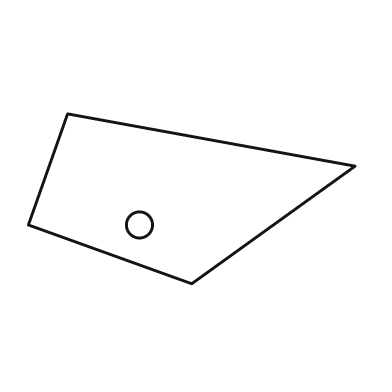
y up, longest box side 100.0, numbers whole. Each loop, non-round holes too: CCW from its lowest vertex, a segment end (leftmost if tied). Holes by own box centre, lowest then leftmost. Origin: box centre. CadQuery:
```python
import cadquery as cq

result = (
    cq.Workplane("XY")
    .moveTo(0.0, -26.0)
    .lineTo(50.0, 10.0)
    .lineTo(-38.0, 26.0)
    .lineTo(-50.0, -8.0)
    .close()
    .moveTo(-16.0, -8.0)
    .circle(4.0)
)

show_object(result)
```